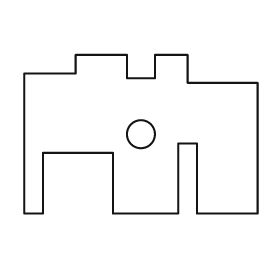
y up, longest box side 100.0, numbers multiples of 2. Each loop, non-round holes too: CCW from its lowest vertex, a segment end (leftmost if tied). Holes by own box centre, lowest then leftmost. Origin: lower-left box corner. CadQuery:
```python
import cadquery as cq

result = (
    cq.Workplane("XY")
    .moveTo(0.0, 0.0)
    .lineTo(8.0, 0.0)
    .lineTo(8.0, 26.0)
    .lineTo(38.0, 26.0)
    .lineTo(38.0, 0.0)
    .lineTo(66.0, 0.0)
    .lineTo(66.0, 30.0)
    .lineTo(74.0, 30.0)
    .lineTo(74.0, 0.0)
    .lineTo(100.0, 0.0)
    .lineTo(100.0, 56.0)
    .lineTo(70.0, 56.0)
    .lineTo(70.0, 68.0)
    .lineTo(56.0, 68.0)
    .lineTo(56.0, 58.0)
    .lineTo(44.0, 58.0)
    .lineTo(44.0, 68.0)
    .lineTo(22.0, 68.0)
    .lineTo(22.0, 60.0)
    .lineTo(0.0, 60.0)
    .close()
    .moveTo(50.0, 34.0)
    .circle(6.0)
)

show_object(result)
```